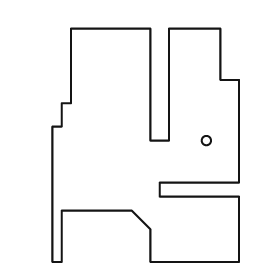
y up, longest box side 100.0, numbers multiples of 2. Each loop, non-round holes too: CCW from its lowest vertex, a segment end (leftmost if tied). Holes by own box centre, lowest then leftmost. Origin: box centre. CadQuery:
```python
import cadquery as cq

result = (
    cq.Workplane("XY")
    .moveTo(-40.0, -50.0)
    .lineTo(-36.0, -50.0)
    .lineTo(-36.0, -28.0)
    .lineTo(-6.0, -28.0)
    .lineTo(2.0, -36.0)
    .lineTo(2.0, -50.0)
    .lineTo(40.0, -50.0)
    .lineTo(40.0, -22.0)
    .lineTo(6.0, -22.0)
    .lineTo(6.0, -16.0)
    .lineTo(40.0, -16.0)
    .lineTo(40.0, 28.0)
    .lineTo(32.0, 28.0)
    .lineTo(32.0, 50.0)
    .lineTo(10.0, 50.0)
    .lineTo(10.0, 2.0)
    .lineTo(2.0, 2.0)
    .lineTo(2.0, 50.0)
    .lineTo(-32.0, 50.0)
    .lineTo(-32.0, 18.0)
    .lineTo(-36.0, 18.0)
    .lineTo(-36.0, 8.0)
    .lineTo(-40.0, 8.0)
    .close()
    .moveTo(26.0, 2.0)
    .circle(2.0)
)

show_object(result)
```